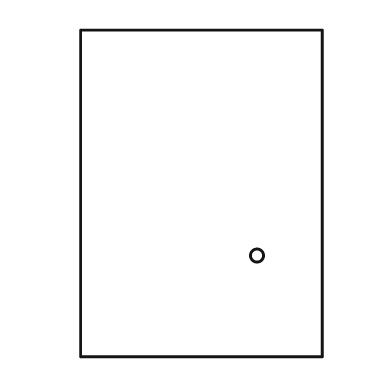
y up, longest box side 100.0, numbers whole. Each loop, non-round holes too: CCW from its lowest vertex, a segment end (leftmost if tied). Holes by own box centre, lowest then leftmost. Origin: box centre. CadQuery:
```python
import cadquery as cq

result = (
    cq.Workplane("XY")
    .moveTo(-37.0, -50.0)
    .lineTo(37.0, -50.0)
    .lineTo(37.0, 50.0)
    .lineTo(-37.0, 50.0)
    .close()
    .moveTo(17.0, -19.0)
    .circle(2.0)
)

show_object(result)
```